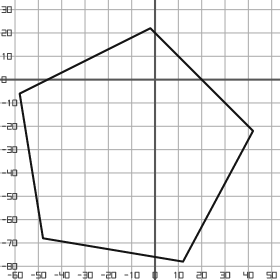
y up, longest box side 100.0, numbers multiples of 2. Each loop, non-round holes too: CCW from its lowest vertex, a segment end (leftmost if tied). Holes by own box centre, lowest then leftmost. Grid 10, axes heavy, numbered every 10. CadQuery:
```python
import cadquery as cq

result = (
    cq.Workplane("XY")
    .moveTo(12.0, -78.0)
    .lineTo(42.0, -22.0)
    .lineTo(-2.0, 22.0)
    .lineTo(-58.0, -6.0)
    .lineTo(-48.0, -68.0)
    .close()
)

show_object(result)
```